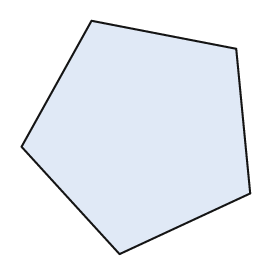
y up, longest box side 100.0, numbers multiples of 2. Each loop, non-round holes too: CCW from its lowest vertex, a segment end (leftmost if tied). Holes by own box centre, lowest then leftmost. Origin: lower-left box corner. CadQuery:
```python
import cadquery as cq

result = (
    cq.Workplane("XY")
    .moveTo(42.0, 0.0)
    .lineTo(98.0, 26.0)
    .lineTo(92.0, 88.0)
    .lineTo(30.0, 100.0)
    .lineTo(0.0, 46.0)
    .close()
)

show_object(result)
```